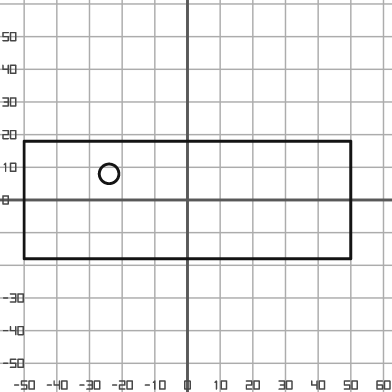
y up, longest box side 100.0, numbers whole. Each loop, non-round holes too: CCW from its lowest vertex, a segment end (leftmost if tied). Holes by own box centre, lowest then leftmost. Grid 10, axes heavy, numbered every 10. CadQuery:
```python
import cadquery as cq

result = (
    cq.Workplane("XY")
    .moveTo(-50.0, -18.0)
    .lineTo(50.0, -18.0)
    .lineTo(50.0, 18.0)
    .lineTo(-50.0, 18.0)
    .close()
    .moveTo(-24.0, 8.0)
    .circle(3.0)
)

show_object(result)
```